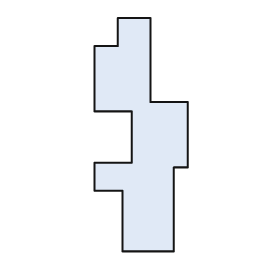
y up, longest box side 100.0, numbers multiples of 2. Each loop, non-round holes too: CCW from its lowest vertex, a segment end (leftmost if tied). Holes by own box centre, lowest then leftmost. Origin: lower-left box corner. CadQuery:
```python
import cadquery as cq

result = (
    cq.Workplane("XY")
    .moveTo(12.0, 0.0)
    .lineTo(34.0, 0.0)
    .lineTo(34.0, 36.0)
    .lineTo(40.0, 36.0)
    .lineTo(40.0, 64.0)
    .lineTo(24.0, 64.0)
    .lineTo(24.0, 100.0)
    .lineTo(10.0, 100.0)
    .lineTo(10.0, 88.0)
    .lineTo(0.0, 88.0)
    .lineTo(0.0, 60.0)
    .lineTo(16.0, 60.0)
    .lineTo(16.0, 38.0)
    .lineTo(0.0, 38.0)
    .lineTo(0.0, 26.0)
    .lineTo(12.0, 26.0)
    .close()
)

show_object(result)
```